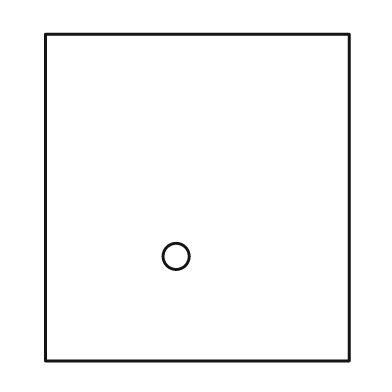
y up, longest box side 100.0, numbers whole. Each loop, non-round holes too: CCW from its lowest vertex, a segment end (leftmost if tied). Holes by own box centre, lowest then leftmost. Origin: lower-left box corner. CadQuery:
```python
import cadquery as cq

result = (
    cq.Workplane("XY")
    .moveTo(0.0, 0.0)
    .lineTo(93.0, 0.0)
    .lineTo(93.0, 100.0)
    .lineTo(0.0, 100.0)
    .close()
    .moveTo(40.0, 32.0)
    .circle(4.0)
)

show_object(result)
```